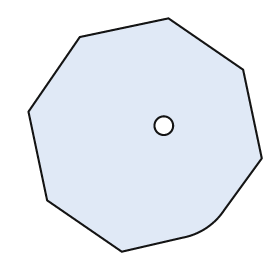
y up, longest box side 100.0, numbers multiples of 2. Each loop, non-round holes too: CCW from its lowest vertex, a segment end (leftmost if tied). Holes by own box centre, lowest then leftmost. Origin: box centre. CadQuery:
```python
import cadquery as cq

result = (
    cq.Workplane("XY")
    .moveTo(-10.0, -50.0)
    .lineTo(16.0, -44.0)
    .threePointArc((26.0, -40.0), (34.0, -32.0))
    .lineTo(50.0, -10.0)
    .lineTo(42.0, 28.0)
    .lineTo(10.0, 50.0)
    .lineTo(-28.0, 42.0)
    .lineTo(-50.0, 10.0)
    .lineTo(-42.0, -28.0)
    .close()
    .moveTo(8.0, 4.0)
    .circle(4.0)
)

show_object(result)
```